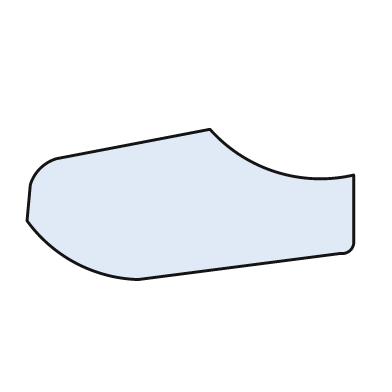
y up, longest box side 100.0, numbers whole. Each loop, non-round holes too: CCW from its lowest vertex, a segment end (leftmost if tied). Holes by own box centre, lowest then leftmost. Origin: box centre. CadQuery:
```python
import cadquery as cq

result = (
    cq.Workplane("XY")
    .moveTo(-16.0, -23.0)
    .lineTo(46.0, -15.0)
    .threePointArc((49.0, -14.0), (50.0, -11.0))
    .lineTo(50.0, 9.0)
    .threePointArc((26.0, 10.0), (6.0, 23.0))
    .lineTo(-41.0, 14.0)
    .threePointArc((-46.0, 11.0), (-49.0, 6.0))
    .lineTo(-50.0, -5.0)
    .threePointArc((-35.0, -18.0), (-16.0, -23.0))
    .close()
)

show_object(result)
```